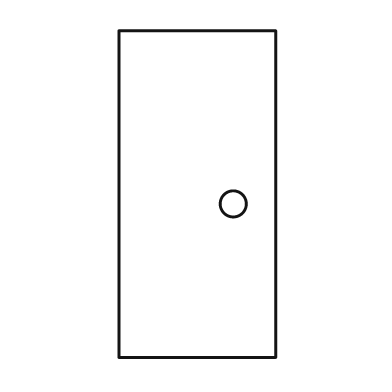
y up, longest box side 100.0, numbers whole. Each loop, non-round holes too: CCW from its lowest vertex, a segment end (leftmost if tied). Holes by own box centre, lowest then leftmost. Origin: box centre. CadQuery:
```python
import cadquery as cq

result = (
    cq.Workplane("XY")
    .moveTo(-24.0, -50.0)
    .lineTo(24.0, -50.0)
    .lineTo(24.0, 50.0)
    .lineTo(-24.0, 50.0)
    .close()
    .moveTo(11.0, -3.0)
    .circle(4.0)
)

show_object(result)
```